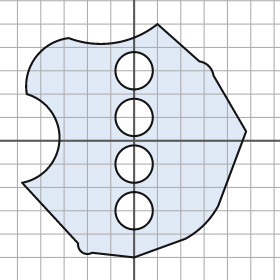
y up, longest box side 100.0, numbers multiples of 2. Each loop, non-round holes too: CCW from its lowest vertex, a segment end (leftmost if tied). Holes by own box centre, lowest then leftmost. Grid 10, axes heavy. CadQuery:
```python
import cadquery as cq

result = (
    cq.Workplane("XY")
    .moveTo(0.0, -50.0)
    .lineTo(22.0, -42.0)
    .threePointArc((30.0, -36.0), (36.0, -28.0))
    .lineTo(48.0, 4.0)
    .lineTo(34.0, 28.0)
    .threePointArc((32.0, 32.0), (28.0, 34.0))
    .lineTo(10.0, 50.0)
    .threePointArc((-8.0, 42.0), (-28.0, 44.0))
    .threePointArc((-42.0, 36.0), (-46.0, 20.0))
    .threePointArc((-32.0, 0.0), (-48.0, -18.0))
    .lineTo(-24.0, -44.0)
    .threePointArc((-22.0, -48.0), (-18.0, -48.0))
    .close()
    .moveTo(0.0, -30.0)
    .circle(8.0)
    .moveTo(0.0, -10.0)
    .circle(8.0)
    .moveTo(0.0, 10.0)
    .circle(8.0)
    .moveTo(0.0, 30.0)
    .circle(8.0)
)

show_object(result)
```